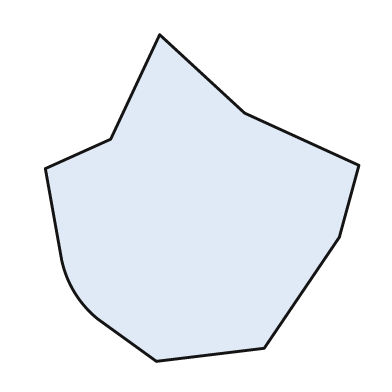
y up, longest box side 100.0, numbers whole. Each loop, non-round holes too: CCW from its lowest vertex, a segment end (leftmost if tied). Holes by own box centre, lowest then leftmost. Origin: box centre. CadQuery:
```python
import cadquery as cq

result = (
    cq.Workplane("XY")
    .moveTo(-14.0, -50.0)
    .lineTo(19.0, -46.0)
    .lineTo(42.0, -12.0)
    .lineTo(48.0, 10.0)
    .lineTo(13.0, 26.0)
    .lineTo(-13.0, 50.0)
    .lineTo(-28.0, 18.0)
    .lineTo(-48.0, 9.0)
    .lineTo(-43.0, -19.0)
    .threePointArc((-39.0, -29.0), (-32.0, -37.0))
    .close()
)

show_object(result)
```